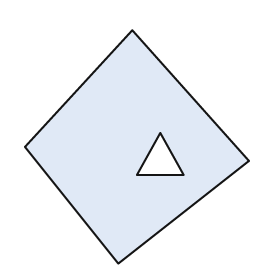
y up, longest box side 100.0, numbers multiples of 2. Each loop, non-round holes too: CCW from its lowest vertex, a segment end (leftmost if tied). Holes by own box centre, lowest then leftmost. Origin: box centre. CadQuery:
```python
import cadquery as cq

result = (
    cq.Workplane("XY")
    .moveTo(-8.0, -50.0)
    .lineTo(48.0, -6.0)
    .lineTo(-2.0, 50.0)
    .lineTo(-48.0, 0.0)
    .close()
    .moveTo(0.0, -12.0)
    .lineTo(20.0, -12.0)
    .lineTo(10.0, 6.0)
    .close()
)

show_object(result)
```